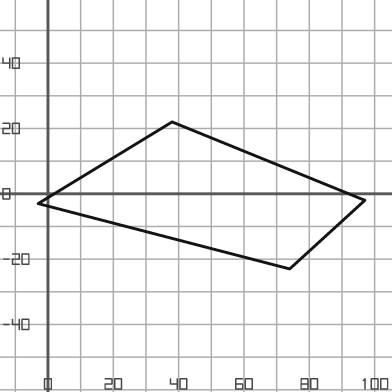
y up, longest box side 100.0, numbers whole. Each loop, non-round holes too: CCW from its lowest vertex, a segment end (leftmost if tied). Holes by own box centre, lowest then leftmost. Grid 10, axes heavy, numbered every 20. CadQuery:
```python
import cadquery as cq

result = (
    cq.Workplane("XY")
    .moveTo(74.0, -23.0)
    .lineTo(97.0, -2.0)
    .lineTo(38.0, 22.0)
    .lineTo(-3.0, -3.0)
    .close()
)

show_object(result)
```